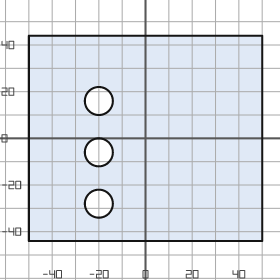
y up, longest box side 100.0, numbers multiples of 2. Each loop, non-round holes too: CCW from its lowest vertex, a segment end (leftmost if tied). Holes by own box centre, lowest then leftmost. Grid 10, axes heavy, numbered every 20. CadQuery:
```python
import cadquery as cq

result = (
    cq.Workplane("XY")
    .moveTo(-50.0, -44.0)
    .lineTo(50.0, -44.0)
    .lineTo(50.0, 44.0)
    .lineTo(-50.0, 44.0)
    .close()
    .moveTo(-20.0, -28.0)
    .circle(6.0)
    .moveTo(-20.0, -6.0)
    .circle(6.0)
    .moveTo(-20.0, 16.0)
    .circle(6.0)
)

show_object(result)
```